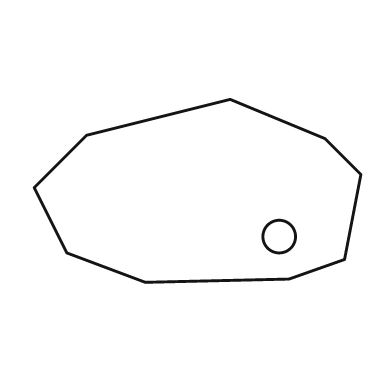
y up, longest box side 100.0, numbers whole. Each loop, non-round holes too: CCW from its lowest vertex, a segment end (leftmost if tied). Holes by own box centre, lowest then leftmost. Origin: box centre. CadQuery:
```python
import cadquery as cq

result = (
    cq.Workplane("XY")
    .moveTo(-16.0, -28.0)
    .lineTo(28.0, -27.0)
    .lineTo(45.0, -21.0)
    .lineTo(50.0, 5.0)
    .lineTo(39.0, 16.0)
    .lineTo(10.0, 28.0)
    .lineTo(-34.0, 17.0)
    .lineTo(-50.0, 1.0)
    .lineTo(-40.0, -19.0)
    .close()
    .moveTo(25.0, -14.0)
    .circle(5.0)
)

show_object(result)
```